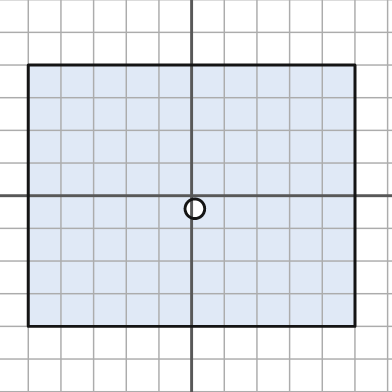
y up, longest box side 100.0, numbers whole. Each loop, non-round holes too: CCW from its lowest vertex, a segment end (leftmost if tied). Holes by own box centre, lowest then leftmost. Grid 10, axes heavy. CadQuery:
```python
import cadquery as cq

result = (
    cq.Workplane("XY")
    .moveTo(-50.0, -40.0)
    .lineTo(50.0, -40.0)
    .lineTo(50.0, 40.0)
    .lineTo(-50.0, 40.0)
    .close()
    .moveTo(1.0, -4.0)
    .circle(3.0)
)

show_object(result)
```